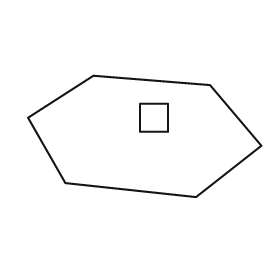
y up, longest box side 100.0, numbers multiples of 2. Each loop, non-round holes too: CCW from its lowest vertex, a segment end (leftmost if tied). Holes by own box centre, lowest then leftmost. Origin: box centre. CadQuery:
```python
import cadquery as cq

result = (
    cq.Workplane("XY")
    .moveTo(22.0, -26.0)
    .lineTo(50.0, -4.0)
    .lineTo(28.0, 22.0)
    .lineTo(-22.0, 26.0)
    .lineTo(-50.0, 8.0)
    .lineTo(-34.0, -20.0)
    .close()
    .moveTo(-2.0, 2.0)
    .lineTo(10.0, 2.0)
    .lineTo(10.0, 14.0)
    .lineTo(-2.0, 14.0)
    .close()
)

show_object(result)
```